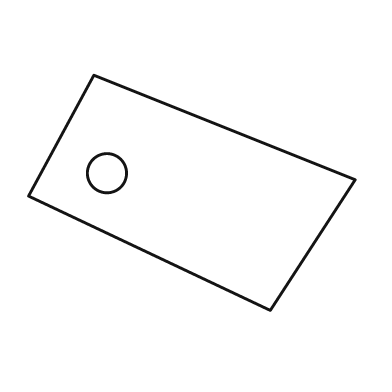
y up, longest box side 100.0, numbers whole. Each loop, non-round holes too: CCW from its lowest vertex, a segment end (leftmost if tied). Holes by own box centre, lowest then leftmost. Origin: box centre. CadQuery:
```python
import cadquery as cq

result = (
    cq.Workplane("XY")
    .moveTo(24.0, -36.0)
    .lineTo(50.0, 4.0)
    .lineTo(-30.0, 36.0)
    .lineTo(-50.0, -1.0)
    .close()
    .moveTo(-26.0, 6.0)
    .circle(6.0)
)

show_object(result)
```